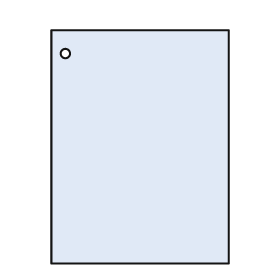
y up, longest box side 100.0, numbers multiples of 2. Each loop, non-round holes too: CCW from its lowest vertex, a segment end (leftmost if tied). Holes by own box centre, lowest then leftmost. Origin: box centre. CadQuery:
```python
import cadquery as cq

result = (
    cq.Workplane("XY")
    .moveTo(-38.0, -50.0)
    .lineTo(38.0, -50.0)
    .lineTo(38.0, 50.0)
    .lineTo(-38.0, 50.0)
    .close()
    .moveTo(-32.0, 40.0)
    .circle(2.0)
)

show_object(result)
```